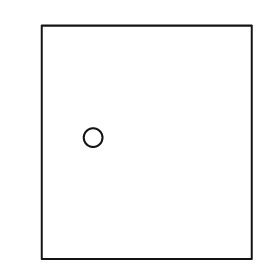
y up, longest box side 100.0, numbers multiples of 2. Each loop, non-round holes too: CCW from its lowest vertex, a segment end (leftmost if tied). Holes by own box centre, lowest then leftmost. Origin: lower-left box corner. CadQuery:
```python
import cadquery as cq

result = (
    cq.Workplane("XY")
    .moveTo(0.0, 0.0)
    .lineTo(90.0, 0.0)
    .lineTo(90.0, 100.0)
    .lineTo(0.0, 100.0)
    .close()
    .moveTo(22.0, 52.0)
    .circle(4.0)
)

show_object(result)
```